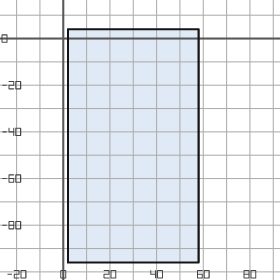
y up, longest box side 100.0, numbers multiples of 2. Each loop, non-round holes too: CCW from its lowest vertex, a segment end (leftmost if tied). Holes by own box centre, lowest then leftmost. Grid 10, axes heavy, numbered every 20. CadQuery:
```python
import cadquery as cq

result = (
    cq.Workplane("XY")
    .moveTo(2.0, -96.0)
    .lineTo(58.0, -96.0)
    .lineTo(58.0, 4.0)
    .lineTo(2.0, 4.0)
    .close()
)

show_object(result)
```